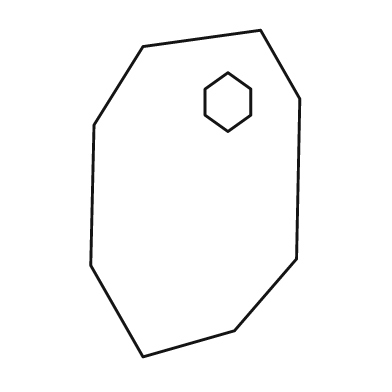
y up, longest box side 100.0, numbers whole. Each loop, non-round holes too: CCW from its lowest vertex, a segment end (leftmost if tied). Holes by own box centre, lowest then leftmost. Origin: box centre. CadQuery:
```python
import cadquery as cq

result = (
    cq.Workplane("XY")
    .moveTo(-16.0, -50.0)
    .lineTo(12.0, -42.0)
    .lineTo(31.0, -20.0)
    .lineTo(32.0, 29.0)
    .lineTo(20.0, 50.0)
    .lineTo(-16.0, 45.0)
    .lineTo(-31.0, 21.0)
    .lineTo(-32.0, -22.0)
    .close()
    .moveTo(10.0, 19.0)
    .lineTo(17.0, 24.0)
    .lineTo(17.0, 32.0)
    .lineTo(10.0, 37.0)
    .lineTo(3.0, 32.0)
    .lineTo(3.0, 24.0)
    .close()
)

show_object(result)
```